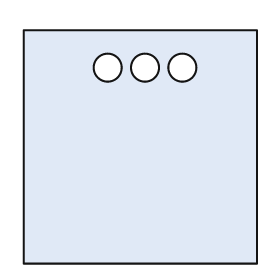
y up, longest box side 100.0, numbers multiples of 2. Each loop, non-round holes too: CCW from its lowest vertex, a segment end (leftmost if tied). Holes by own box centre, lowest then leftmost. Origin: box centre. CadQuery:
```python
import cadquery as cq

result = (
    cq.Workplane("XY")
    .moveTo(-50.0, -50.0)
    .lineTo(50.0, -50.0)
    .lineTo(50.0, 50.0)
    .lineTo(-50.0, 50.0)
    .close()
    .moveTo(-14.0, 34.0)
    .circle(6.0)
    .moveTo(2.0, 34.0)
    .circle(6.0)
    .moveTo(18.0, 34.0)
    .circle(6.0)
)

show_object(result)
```